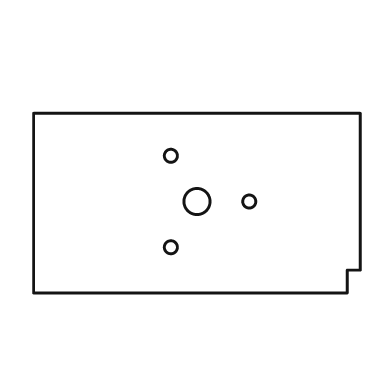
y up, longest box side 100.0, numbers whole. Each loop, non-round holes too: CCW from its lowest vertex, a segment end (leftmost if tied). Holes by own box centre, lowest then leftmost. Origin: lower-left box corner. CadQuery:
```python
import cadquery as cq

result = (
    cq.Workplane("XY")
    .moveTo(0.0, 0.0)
    .lineTo(96.0, 0.0)
    .lineTo(96.0, 7.0)
    .lineTo(100.0, 7.0)
    .lineTo(100.0, 55.0)
    .lineTo(0.0, 55.0)
    .close()
    .moveTo(42.0, 14.0)
    .circle(2.0)
    .moveTo(50.0, 28.0)
    .circle(4.0)
    .moveTo(66.0, 28.0)
    .circle(2.0)
    .moveTo(42.0, 42.0)
    .circle(2.0)
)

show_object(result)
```